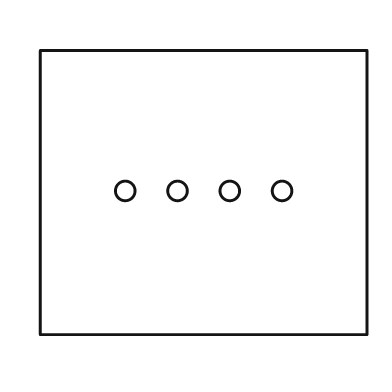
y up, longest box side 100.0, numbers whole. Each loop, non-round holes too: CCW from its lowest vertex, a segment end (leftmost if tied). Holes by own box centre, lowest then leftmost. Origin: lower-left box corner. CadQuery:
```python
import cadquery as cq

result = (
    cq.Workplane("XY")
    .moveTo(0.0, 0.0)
    .lineTo(100.0, 0.0)
    .lineTo(100.0, 87.0)
    .lineTo(0.0, 87.0)
    .close()
    .moveTo(26.0, 44.0)
    .circle(3.0)
    .moveTo(42.0, 44.0)
    .circle(3.0)
    .moveTo(58.0, 44.0)
    .circle(3.0)
    .moveTo(74.0, 44.0)
    .circle(3.0)
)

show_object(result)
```